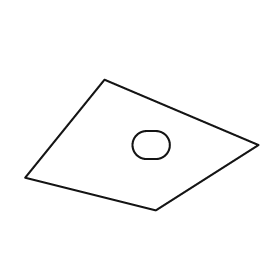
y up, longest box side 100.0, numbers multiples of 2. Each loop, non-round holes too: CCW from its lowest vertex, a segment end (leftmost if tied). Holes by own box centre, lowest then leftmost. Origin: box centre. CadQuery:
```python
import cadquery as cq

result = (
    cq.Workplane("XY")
    .moveTo(6.0, -28.0)
    .lineTo(50.0, 0.0)
    .lineTo(-16.0, 28.0)
    .lineTo(-50.0, -14.0)
    .close()
    .moveTo(2.0, -6.0)
    .lineTo(6.0, -6.0)
    .threePointArc((12.0, 0.0), (6.0, 6.0))
    .lineTo(2.0, 6.0)
    .threePointArc((-4.0, 0.0), (2.0, -6.0))
    .close()
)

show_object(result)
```